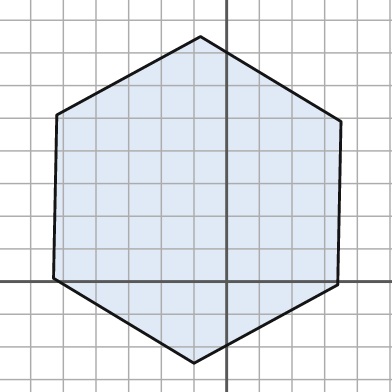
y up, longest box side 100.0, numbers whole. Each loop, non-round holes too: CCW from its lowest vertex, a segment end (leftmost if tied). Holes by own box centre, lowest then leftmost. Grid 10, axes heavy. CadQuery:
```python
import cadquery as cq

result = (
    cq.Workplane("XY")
    .moveTo(-10.0, -25.0)
    .lineTo(34.0, -1.0)
    .lineTo(35.0, 49.0)
    .lineTo(-8.0, 75.0)
    .lineTo(-52.0, 51.0)
    .lineTo(-53.0, 1.0)
    .close()
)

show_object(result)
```